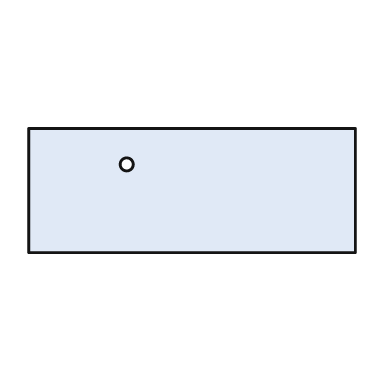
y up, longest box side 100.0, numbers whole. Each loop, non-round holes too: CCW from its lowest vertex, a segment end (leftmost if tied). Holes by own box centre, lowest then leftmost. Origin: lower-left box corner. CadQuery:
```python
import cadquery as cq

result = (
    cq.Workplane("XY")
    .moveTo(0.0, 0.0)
    .lineTo(100.0, 0.0)
    .lineTo(100.0, 38.0)
    .lineTo(0.0, 38.0)
    .close()
    .moveTo(30.0, 27.0)
    .circle(2.0)
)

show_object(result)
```